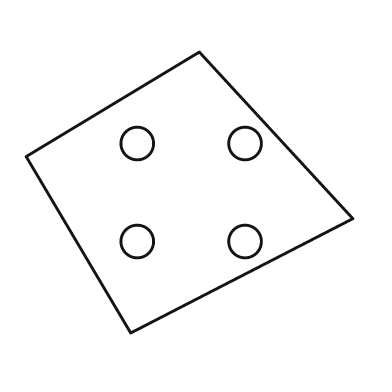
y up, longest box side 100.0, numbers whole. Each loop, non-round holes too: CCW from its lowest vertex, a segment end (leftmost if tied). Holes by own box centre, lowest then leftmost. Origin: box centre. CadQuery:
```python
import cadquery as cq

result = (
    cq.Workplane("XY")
    .moveTo(-18.0, -43.0)
    .lineTo(50.0, -8.0)
    .lineTo(3.0, 43.0)
    .lineTo(-50.0, 11.0)
    .close()
    .moveTo(-16.0, -15.0)
    .circle(5.0)
    .moveTo(17.0, -15.0)
    .circle(5.0)
    .moveTo(-16.0, 15.0)
    .circle(5.0)
    .moveTo(17.0, 15.0)
    .circle(5.0)
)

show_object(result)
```